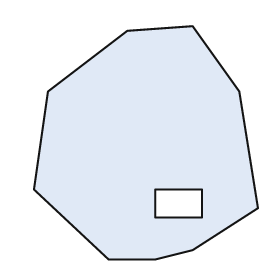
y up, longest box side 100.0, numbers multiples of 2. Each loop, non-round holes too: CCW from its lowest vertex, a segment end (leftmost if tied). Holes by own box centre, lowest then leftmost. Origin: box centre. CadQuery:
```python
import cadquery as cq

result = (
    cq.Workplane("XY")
    .moveTo(-16.0, -50.0)
    .lineTo(4.0, -50.0)
    .lineTo(20.0, -46.0)
    .lineTo(48.0, -28.0)
    .lineTo(40.0, 22.0)
    .lineTo(20.0, 50.0)
    .lineTo(-8.0, 48.0)
    .lineTo(-42.0, 22.0)
    .lineTo(-48.0, -20.0)
    .close()
    .moveTo(4.0, -32.0)
    .lineTo(24.0, -32.0)
    .lineTo(24.0, -20.0)
    .lineTo(4.0, -20.0)
    .close()
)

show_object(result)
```